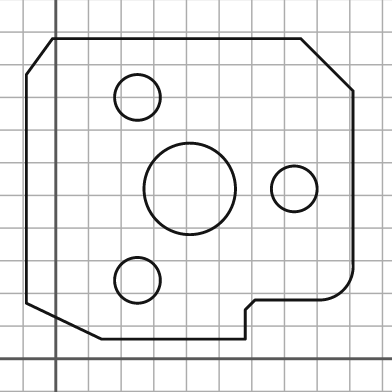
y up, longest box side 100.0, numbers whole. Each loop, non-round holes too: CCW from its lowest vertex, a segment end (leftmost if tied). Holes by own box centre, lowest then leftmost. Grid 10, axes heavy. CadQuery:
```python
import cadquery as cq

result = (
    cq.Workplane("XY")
    .moveTo(14.0, 6.0)
    .lineTo(58.0, 6.0)
    .lineTo(58.0, 15.0)
    .lineTo(61.0, 18.0)
    .lineTo(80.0, 18.0)
    .threePointArc((88.0, 21.0), (91.0, 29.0))
    .lineTo(91.0, 82.0)
    .lineTo(75.0, 98.0)
    .lineTo(-1.0, 98.0)
    .lineTo(-9.0, 87.0)
    .lineTo(-9.0, 17.0)
    .close()
    .moveTo(25.0, 24.0)
    .circle(7.0)
    .moveTo(41.0, 52.0)
    .circle(14.0)
    .moveTo(73.0, 52.0)
    .circle(7.0)
    .moveTo(25.0, 80.0)
    .circle(7.0)
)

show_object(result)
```